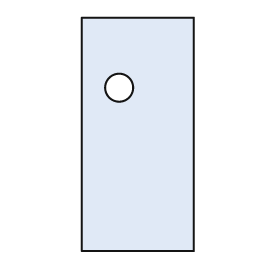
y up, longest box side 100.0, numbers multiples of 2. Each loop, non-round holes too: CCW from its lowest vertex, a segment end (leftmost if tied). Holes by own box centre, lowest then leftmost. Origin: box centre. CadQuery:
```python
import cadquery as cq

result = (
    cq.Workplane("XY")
    .moveTo(-24.0, -50.0)
    .lineTo(24.0, -50.0)
    .lineTo(24.0, 50.0)
    .lineTo(-24.0, 50.0)
    .close()
    .moveTo(-8.0, 20.0)
    .circle(6.0)
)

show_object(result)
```